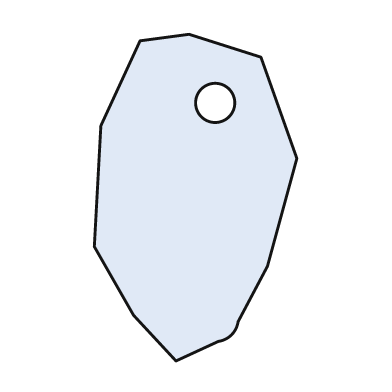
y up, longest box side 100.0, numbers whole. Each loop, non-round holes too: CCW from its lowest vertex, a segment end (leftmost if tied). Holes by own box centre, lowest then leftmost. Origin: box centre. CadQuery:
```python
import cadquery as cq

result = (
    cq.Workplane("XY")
    .moveTo(-6.0, -50.0)
    .lineTo(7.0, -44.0)
    .threePointArc((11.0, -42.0), (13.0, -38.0))
    .lineTo(22.0, -21.0)
    .lineTo(31.0, 12.0)
    .lineTo(20.0, 43.0)
    .lineTo(-2.0, 50.0)
    .lineTo(-17.0, 48.0)
    .lineTo(-29.0, 22.0)
    .lineTo(-31.0, -15.0)
    .lineTo(-19.0, -36.0)
    .close()
    .moveTo(6.0, 29.0)
    .circle(6.0)
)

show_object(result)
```